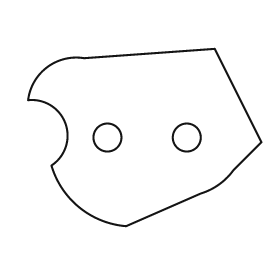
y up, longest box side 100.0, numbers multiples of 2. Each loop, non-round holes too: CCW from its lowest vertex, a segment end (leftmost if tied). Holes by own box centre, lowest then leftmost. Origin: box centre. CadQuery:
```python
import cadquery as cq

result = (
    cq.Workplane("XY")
    .moveTo(-8.0, -38.0)
    .lineTo(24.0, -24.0)
    .threePointArc((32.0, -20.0), (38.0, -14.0))
    .lineTo(50.0, -2.0)
    .lineTo(30.0, 38.0)
    .lineTo(-26.0, 34.0)
    .threePointArc((-42.0, 30.0), (-50.0, 16.0))
    .threePointArc((-34.0, 6.0), (-40.0, -12.0))
    .threePointArc((-28.0, -30.0), (-8.0, -38.0))
    .close()
    .moveTo(-16.0, 0.0)
    .circle(6.0)
    .moveTo(18.0, 0.0)
    .circle(6.0)
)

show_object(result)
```